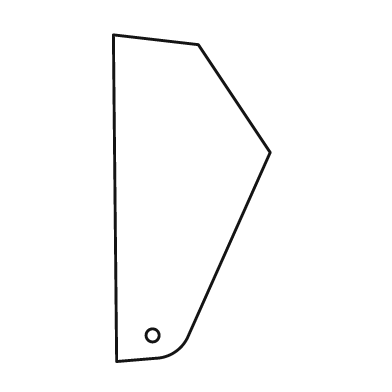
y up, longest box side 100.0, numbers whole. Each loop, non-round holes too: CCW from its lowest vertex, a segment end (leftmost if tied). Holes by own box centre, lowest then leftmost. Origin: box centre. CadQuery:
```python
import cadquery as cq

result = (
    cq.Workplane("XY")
    .moveTo(-23.0, -50.0)
    .lineTo(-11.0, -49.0)
    .threePointArc((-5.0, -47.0), (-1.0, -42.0))
    .lineTo(24.0, 14.0)
    .lineTo(2.0, 47.0)
    .lineTo(-24.0, 50.0)
    .close()
    .moveTo(-12.0, -42.0)
    .circle(2.0)
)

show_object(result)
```